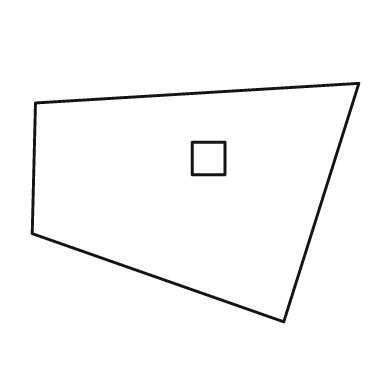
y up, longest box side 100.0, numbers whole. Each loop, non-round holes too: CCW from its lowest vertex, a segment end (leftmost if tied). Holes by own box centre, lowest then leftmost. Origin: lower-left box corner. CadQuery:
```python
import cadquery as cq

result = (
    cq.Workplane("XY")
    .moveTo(77.0, 0.0)
    .lineTo(100.0, 73.0)
    .lineTo(1.0, 67.0)
    .lineTo(0.0, 27.0)
    .close()
    .moveTo(49.0, 45.0)
    .lineTo(59.0, 45.0)
    .lineTo(59.0, 55.0)
    .lineTo(49.0, 55.0)
    .close()
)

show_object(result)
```